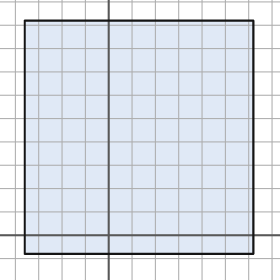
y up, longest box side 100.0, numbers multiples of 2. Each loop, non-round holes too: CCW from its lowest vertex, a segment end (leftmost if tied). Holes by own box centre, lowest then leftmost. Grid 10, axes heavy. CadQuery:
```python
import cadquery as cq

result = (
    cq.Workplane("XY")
    .moveTo(-36.0, -8.0)
    .lineTo(62.0, -8.0)
    .lineTo(62.0, 92.0)
    .lineTo(-36.0, 92.0)
    .close()
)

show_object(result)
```